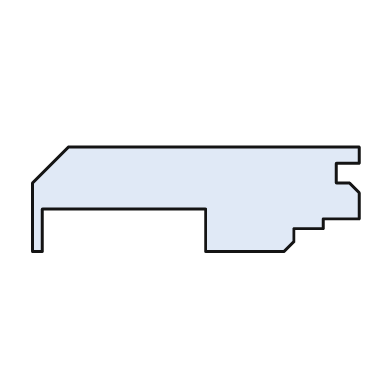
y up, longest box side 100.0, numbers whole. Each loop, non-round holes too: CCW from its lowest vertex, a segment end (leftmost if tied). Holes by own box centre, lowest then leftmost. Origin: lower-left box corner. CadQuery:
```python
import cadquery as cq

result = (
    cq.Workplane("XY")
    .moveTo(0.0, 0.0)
    .lineTo(3.0, 0.0)
    .lineTo(3.0, 13.0)
    .lineTo(53.0, 13.0)
    .lineTo(53.0, 0.0)
    .lineTo(77.0, 0.0)
    .lineTo(80.0, 3.0)
    .lineTo(80.0, 7.0)
    .lineTo(89.0, 7.0)
    .lineTo(89.0, 10.0)
    .lineTo(100.0, 10.0)
    .lineTo(100.0, 18.0)
    .lineTo(97.0, 21.0)
    .lineTo(93.0, 21.0)
    .lineTo(93.0, 27.0)
    .lineTo(100.0, 27.0)
    .lineTo(100.0, 32.0)
    .lineTo(11.0, 32.0)
    .lineTo(0.0, 21.0)
    .close()
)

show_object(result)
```